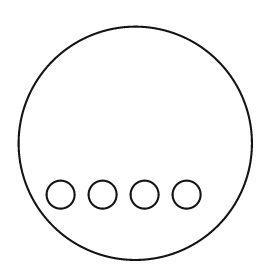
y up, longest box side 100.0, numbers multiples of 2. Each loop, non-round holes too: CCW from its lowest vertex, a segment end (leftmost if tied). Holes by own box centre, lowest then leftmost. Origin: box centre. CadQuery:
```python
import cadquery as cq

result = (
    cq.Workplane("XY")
    .moveTo(0.0, 0.0)
    .circle(50.0)
    .moveTo(-32.0, -22.0)
    .circle(6.0)
    .moveTo(-14.0, -22.0)
    .circle(6.0)
    .moveTo(4.0, -22.0)
    .circle(6.0)
    .moveTo(22.0, -22.0)
    .circle(6.0)
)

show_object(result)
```